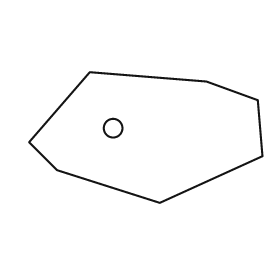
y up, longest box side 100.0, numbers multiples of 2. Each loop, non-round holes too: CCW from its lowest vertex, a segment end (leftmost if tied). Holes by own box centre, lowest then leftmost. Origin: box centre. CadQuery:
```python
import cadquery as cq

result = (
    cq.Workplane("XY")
    .moveTo(6.0, -28.0)
    .lineTo(50.0, -8.0)
    .lineTo(48.0, 16.0)
    .lineTo(26.0, 24.0)
    .lineTo(-24.0, 28.0)
    .lineTo(-50.0, -2.0)
    .lineTo(-38.0, -14.0)
    .close()
    .moveTo(-14.0, 4.0)
    .circle(4.0)
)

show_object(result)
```